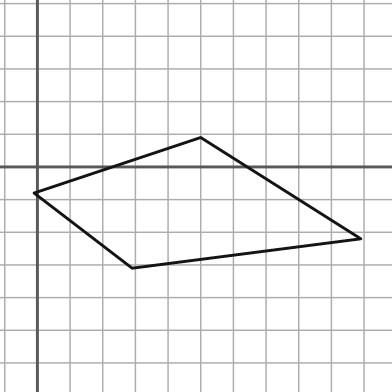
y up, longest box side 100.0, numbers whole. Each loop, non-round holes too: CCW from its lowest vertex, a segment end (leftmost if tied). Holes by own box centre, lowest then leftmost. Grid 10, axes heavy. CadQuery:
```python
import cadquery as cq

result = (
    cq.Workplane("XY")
    .moveTo(29.0, -31.0)
    .lineTo(99.0, -22.0)
    .lineTo(50.0, 9.0)
    .lineTo(-1.0, -8.0)
    .close()
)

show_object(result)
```